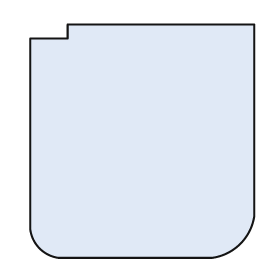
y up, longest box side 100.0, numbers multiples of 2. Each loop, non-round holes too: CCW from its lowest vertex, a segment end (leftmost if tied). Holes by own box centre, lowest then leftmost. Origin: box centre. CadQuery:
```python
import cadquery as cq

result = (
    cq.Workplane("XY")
    .moveTo(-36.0, -50.0)
    .lineTo(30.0, -50.0)
    .threePointArc((42.0, -44.0), (48.0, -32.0))
    .lineTo(48.0, 50.0)
    .lineTo(-32.0, 50.0)
    .lineTo(-32.0, 44.0)
    .lineTo(-48.0, 44.0)
    .lineTo(-48.0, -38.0)
    .threePointArc((-44.0, -46.0), (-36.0, -50.0))
    .close()
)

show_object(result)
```